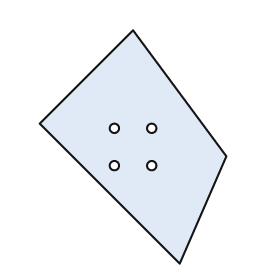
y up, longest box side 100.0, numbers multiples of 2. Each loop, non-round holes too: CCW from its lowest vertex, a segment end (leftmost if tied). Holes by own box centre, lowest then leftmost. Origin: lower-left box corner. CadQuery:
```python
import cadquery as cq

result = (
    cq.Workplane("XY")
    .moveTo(60.0, 0.0)
    .lineTo(80.0, 46.0)
    .lineTo(40.0, 100.0)
    .lineTo(0.0, 60.0)
    .close()
    .moveTo(32.0, 42.0)
    .circle(2.0)
    .moveTo(48.0, 42.0)
    .circle(2.0)
    .moveTo(32.0, 58.0)
    .circle(2.0)
    .moveTo(48.0, 58.0)
    .circle(2.0)
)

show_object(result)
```